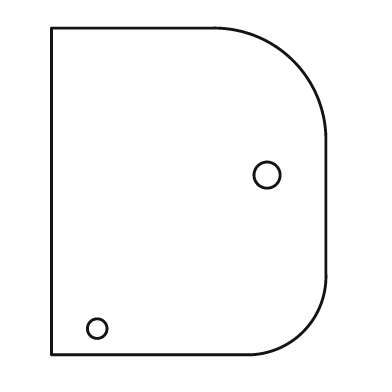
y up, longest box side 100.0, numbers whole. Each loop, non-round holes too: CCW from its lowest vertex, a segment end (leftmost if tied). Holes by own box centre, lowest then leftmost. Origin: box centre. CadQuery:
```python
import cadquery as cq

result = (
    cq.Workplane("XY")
    .moveTo(-42.0, -50.0)
    .lineTo(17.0, -50.0)
    .threePointArc((35.0, -43.0), (42.0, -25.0))
    .lineTo(42.0, 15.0)
    .threePointArc((32.0, 40.0), (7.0, 50.0))
    .lineTo(-42.0, 50.0)
    .close()
    .moveTo(-28.0, -42.0)
    .circle(3.0)
    .moveTo(24.0, 5.0)
    .circle(4.0)
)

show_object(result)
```